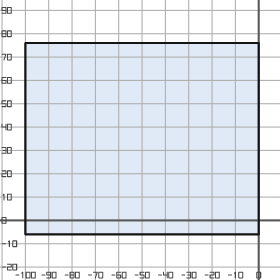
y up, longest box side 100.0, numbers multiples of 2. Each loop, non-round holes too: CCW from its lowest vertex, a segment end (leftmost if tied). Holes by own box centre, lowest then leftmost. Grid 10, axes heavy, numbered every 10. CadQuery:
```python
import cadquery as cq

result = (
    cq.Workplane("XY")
    .moveTo(-100.0, -6.0)
    .lineTo(0.0, -6.0)
    .lineTo(0.0, 76.0)
    .lineTo(-100.0, 76.0)
    .close()
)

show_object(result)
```